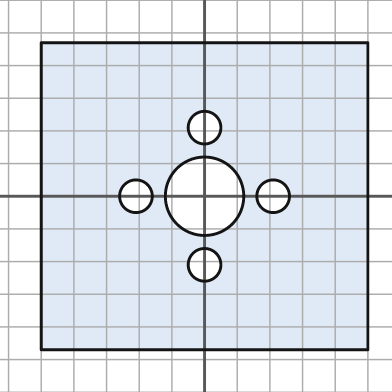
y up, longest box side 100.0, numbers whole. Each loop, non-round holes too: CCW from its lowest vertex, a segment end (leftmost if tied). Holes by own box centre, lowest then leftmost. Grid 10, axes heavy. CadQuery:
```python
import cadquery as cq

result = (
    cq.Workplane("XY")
    .moveTo(-50.0, -47.0)
    .lineTo(50.0, -47.0)
    .lineTo(50.0, 47.0)
    .lineTo(-50.0, 47.0)
    .close()
    .moveTo(0.0, -21.0)
    .circle(5.0)
    .moveTo(-21.0, 0.0)
    .circle(5.0)
    .moveTo(0.0, 0.0)
    .circle(12.0)
    .moveTo(21.0, 0.0)
    .circle(5.0)
    .moveTo(0.0, 21.0)
    .circle(5.0)
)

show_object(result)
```